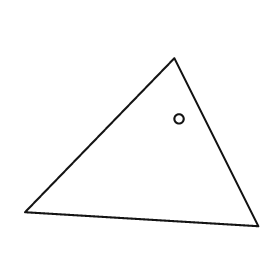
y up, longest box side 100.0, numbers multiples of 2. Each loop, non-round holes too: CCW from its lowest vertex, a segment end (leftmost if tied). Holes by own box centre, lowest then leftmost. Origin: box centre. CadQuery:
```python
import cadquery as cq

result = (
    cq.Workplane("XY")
    .moveTo(50.0, -36.0)
    .lineTo(14.0, 36.0)
    .lineTo(-50.0, -30.0)
    .close()
    .moveTo(16.0, 10.0)
    .circle(2.0)
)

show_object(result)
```